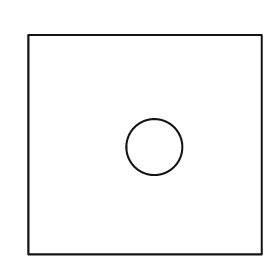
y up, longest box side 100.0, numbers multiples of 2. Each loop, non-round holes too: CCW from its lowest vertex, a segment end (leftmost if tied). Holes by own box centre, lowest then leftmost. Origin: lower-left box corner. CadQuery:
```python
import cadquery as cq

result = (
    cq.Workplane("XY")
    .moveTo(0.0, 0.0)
    .lineTo(100.0, 0.0)
    .lineTo(100.0, 94.0)
    .lineTo(0.0, 94.0)
    .close()
    .moveTo(54.0, 46.0)
    .circle(12.0)
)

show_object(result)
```